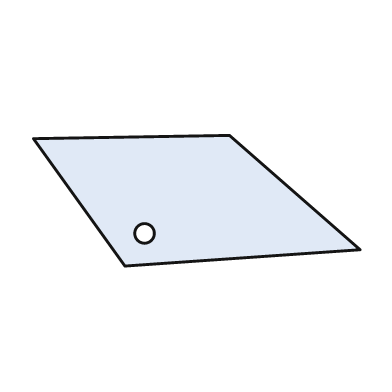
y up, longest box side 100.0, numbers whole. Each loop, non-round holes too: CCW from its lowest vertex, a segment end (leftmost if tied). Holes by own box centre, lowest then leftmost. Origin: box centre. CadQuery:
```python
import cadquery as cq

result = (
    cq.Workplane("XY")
    .moveTo(-22.0, -20.0)
    .lineTo(50.0, -15.0)
    .lineTo(10.0, 20.0)
    .lineTo(-50.0, 19.0)
    .close()
    .moveTo(-16.0, -10.0)
    .circle(3.0)
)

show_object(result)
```